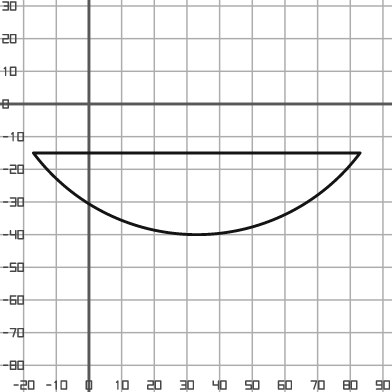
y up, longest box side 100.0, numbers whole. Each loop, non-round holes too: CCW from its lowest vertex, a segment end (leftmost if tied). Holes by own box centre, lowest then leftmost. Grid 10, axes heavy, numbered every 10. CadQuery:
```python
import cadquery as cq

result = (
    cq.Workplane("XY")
    .moveTo(-17.0, -15.0)
    .threePointArc((33.0, -40.0), (83.0, -15.0))
    .close()
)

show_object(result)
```